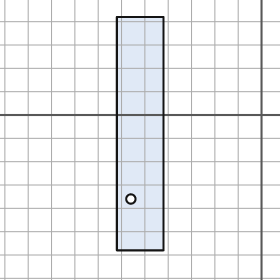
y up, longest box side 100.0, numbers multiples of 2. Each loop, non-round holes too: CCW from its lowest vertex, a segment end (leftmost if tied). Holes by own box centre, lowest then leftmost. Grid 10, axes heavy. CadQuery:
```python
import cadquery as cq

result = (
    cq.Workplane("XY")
    .moveTo(-62.0, -58.0)
    .lineTo(-42.0, -58.0)
    .lineTo(-42.0, 42.0)
    .lineTo(-62.0, 42.0)
    .close()
    .moveTo(-56.0, -36.0)
    .circle(2.0)
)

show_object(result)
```